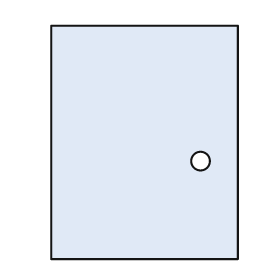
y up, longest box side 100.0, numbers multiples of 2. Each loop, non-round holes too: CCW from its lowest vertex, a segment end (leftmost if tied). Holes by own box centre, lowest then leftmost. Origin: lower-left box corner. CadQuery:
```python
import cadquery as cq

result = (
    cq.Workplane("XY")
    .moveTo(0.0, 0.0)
    .lineTo(80.0, 0.0)
    .lineTo(80.0, 100.0)
    .lineTo(0.0, 100.0)
    .close()
    .moveTo(64.0, 42.0)
    .circle(4.0)
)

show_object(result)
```